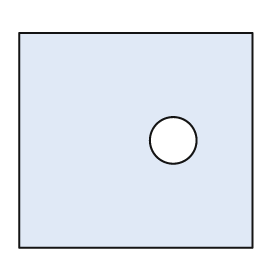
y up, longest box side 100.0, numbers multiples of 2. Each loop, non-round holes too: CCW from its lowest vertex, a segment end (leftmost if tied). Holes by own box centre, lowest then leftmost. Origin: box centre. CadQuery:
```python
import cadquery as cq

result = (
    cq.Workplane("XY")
    .moveTo(-50.0, -46.0)
    .lineTo(50.0, -46.0)
    .lineTo(50.0, 46.0)
    .lineTo(-50.0, 46.0)
    .close()
    .moveTo(16.0, 0.0)
    .circle(10.0)
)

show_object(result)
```